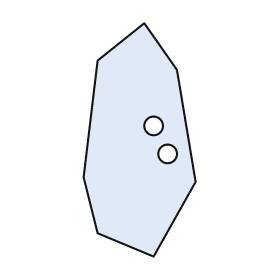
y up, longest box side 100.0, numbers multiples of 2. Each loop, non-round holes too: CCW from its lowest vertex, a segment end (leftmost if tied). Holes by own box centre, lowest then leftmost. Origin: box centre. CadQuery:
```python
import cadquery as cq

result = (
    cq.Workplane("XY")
    .moveTo(6.0, -50.0)
    .lineTo(24.0, -18.0)
    .lineTo(16.0, 30.0)
    .lineTo(2.0, 50.0)
    .lineTo(-18.0, 34.0)
    .lineTo(-24.0, -16.0)
    .lineTo(-18.0, -40.0)
    .close()
    .moveTo(12.0, -6.0)
    .circle(4.0)
    .moveTo(6.0, 6.0)
    .circle(4.0)
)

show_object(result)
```